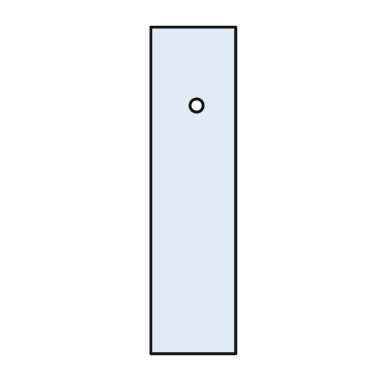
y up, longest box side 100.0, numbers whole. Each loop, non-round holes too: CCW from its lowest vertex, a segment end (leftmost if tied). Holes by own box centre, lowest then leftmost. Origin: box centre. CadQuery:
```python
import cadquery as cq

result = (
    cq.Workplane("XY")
    .moveTo(-13.0, -50.0)
    .lineTo(13.0, -50.0)
    .lineTo(13.0, 50.0)
    .lineTo(-13.0, 50.0)
    .close()
    .moveTo(1.0, 26.0)
    .circle(2.0)
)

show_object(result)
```